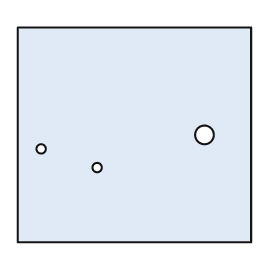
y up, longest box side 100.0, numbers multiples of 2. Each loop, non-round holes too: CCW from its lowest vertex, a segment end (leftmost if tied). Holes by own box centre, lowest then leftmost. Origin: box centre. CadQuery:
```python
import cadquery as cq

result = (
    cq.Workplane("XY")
    .moveTo(-50.0, -46.0)
    .lineTo(50.0, -46.0)
    .lineTo(50.0, 46.0)
    .lineTo(-50.0, 46.0)
    .close()
    .moveTo(-16.0, -14.0)
    .circle(2.0)
    .moveTo(-40.0, -6.0)
    .circle(2.0)
    .moveTo(30.0, 0.0)
    .circle(4.0)
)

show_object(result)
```